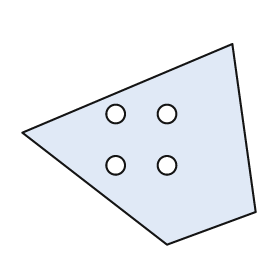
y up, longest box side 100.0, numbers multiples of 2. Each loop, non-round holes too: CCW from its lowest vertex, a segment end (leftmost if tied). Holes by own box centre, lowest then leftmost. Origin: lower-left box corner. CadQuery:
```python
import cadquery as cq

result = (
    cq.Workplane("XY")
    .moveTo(62.0, 0.0)
    .lineTo(100.0, 14.0)
    .lineTo(90.0, 86.0)
    .lineTo(0.0, 48.0)
    .close()
    .moveTo(40.0, 34.0)
    .circle(4.0)
    .moveTo(62.0, 34.0)
    .circle(4.0)
    .moveTo(40.0, 56.0)
    .circle(4.0)
    .moveTo(62.0, 56.0)
    .circle(4.0)
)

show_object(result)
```